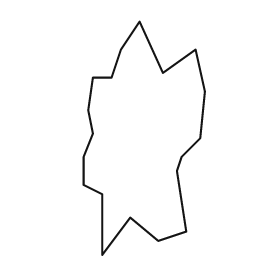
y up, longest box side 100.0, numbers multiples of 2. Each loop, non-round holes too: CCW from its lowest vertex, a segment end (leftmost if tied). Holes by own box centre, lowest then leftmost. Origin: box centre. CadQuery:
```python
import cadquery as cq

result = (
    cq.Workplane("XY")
    .moveTo(-18.0, -50.0)
    .lineTo(-6.0, -34.0)
    .lineTo(6.0, -44.0)
    .lineTo(18.0, -40.0)
    .lineTo(14.0, -14.0)
    .lineTo(16.0, -8.0)
    .lineTo(24.0, 0.0)
    .lineTo(26.0, 20.0)
    .lineTo(22.0, 38.0)
    .lineTo(8.0, 28.0)
    .lineTo(-2.0, 50.0)
    .lineTo(-10.0, 38.0)
    .lineTo(-14.0, 26.0)
    .lineTo(-22.0, 26.0)
    .lineTo(-24.0, 12.0)
    .lineTo(-22.0, 2.0)
    .lineTo(-26.0, -8.0)
    .lineTo(-26.0, -20.0)
    .lineTo(-18.0, -24.0)
    .close()
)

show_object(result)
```